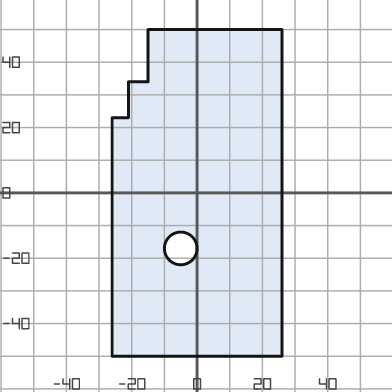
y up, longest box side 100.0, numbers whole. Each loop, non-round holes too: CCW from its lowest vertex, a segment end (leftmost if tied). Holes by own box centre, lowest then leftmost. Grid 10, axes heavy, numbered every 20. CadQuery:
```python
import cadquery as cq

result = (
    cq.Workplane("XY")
    .moveTo(-26.0, -50.0)
    .lineTo(26.0, -50.0)
    .lineTo(26.0, 50.0)
    .lineTo(-15.0, 50.0)
    .lineTo(-15.0, 34.0)
    .lineTo(-21.0, 34.0)
    .lineTo(-21.0, 23.0)
    .lineTo(-26.0, 23.0)
    .close()
    .moveTo(-5.0, -17.0)
    .circle(5.0)
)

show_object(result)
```